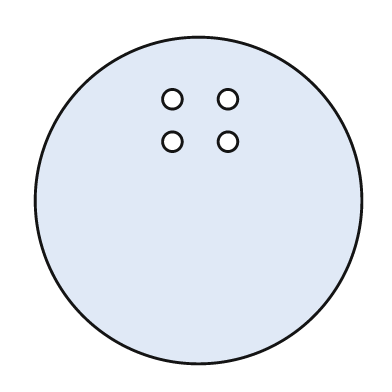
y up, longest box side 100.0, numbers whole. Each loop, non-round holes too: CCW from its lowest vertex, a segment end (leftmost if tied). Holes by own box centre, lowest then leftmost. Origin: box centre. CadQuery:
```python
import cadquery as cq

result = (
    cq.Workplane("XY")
    .moveTo(0.0, 0.0)
    .circle(50.0)
    .moveTo(-8.0, 18.0)
    .circle(3.0)
    .moveTo(9.0, 18.0)
    .circle(3.0)
    .moveTo(-8.0, 31.0)
    .circle(3.0)
    .moveTo(9.0, 31.0)
    .circle(3.0)
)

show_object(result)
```